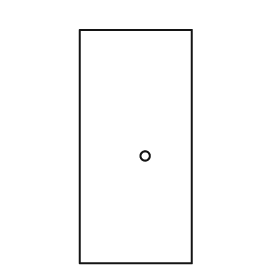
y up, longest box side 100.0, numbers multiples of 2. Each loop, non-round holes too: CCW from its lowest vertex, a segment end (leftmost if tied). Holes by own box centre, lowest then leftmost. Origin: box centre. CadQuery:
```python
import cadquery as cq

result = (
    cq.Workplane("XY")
    .moveTo(-24.0, -50.0)
    .lineTo(24.0, -50.0)
    .lineTo(24.0, 50.0)
    .lineTo(-24.0, 50.0)
    .close()
    .moveTo(4.0, -4.0)
    .circle(2.0)
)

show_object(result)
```